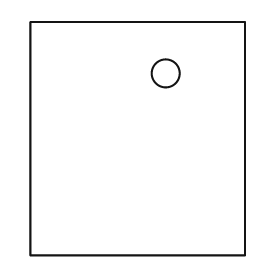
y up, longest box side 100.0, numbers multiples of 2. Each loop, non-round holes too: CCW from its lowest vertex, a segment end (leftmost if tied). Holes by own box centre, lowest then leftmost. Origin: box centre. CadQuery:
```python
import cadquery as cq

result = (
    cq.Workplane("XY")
    .moveTo(-46.0, -50.0)
    .lineTo(46.0, -50.0)
    .lineTo(46.0, 50.0)
    .lineTo(-46.0, 50.0)
    .close()
    .moveTo(12.0, 28.0)
    .circle(6.0)
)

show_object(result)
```